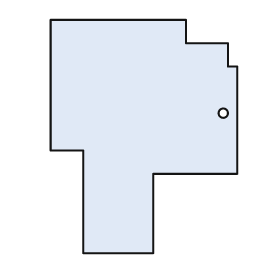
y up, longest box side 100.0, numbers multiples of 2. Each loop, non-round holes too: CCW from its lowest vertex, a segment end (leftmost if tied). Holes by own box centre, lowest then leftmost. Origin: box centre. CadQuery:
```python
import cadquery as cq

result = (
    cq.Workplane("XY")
    .moveTo(-26.0, -50.0)
    .lineTo(4.0, -50.0)
    .lineTo(4.0, -16.0)
    .lineTo(40.0, -16.0)
    .lineTo(40.0, 30.0)
    .lineTo(36.0, 30.0)
    .lineTo(36.0, 40.0)
    .lineTo(18.0, 40.0)
    .lineTo(18.0, 50.0)
    .lineTo(-40.0, 50.0)
    .lineTo(-40.0, -6.0)
    .lineTo(-26.0, -6.0)
    .close()
    .moveTo(34.0, 10.0)
    .circle(2.0)
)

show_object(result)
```